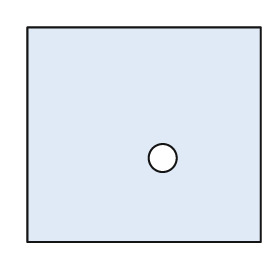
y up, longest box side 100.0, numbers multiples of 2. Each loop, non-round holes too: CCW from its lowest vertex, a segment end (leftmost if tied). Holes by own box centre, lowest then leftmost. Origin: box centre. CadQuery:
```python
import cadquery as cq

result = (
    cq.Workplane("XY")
    .moveTo(-50.0, -46.0)
    .lineTo(50.0, -46.0)
    .lineTo(50.0, 46.0)
    .lineTo(-50.0, 46.0)
    .close()
    .moveTo(8.0, -10.0)
    .circle(6.0)
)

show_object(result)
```